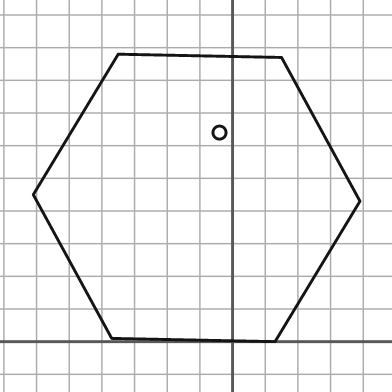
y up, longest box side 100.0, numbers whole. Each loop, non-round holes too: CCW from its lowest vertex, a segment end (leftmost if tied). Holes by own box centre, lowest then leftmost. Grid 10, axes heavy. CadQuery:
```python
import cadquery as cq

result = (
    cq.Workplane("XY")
    .moveTo(13.0, 0.0)
    .lineTo(39.0, 43.0)
    .lineTo(15.0, 87.0)
    .lineTo(-35.0, 88.0)
    .lineTo(-61.0, 45.0)
    .lineTo(-37.0, 1.0)
    .close()
    .moveTo(-4.0, 64.0)
    .circle(2.0)
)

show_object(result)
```